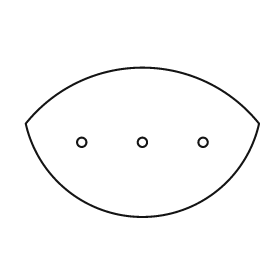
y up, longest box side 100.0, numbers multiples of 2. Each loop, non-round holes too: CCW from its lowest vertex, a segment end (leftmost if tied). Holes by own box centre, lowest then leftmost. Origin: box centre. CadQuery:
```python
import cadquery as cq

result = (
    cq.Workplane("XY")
    .moveTo(-50.0, 8.0)
    .threePointArc((0.0, -32.0), (50.0, 8.0))
    .threePointArc((0.0, 32.0), (-50.0, 8.0))
    .close()
    .moveTo(-26.0, 0.0)
    .circle(2.0)
    .moveTo(0.0, 0.0)
    .circle(2.0)
    .moveTo(26.0, 0.0)
    .circle(2.0)
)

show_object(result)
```